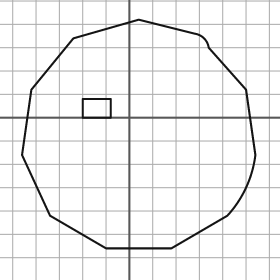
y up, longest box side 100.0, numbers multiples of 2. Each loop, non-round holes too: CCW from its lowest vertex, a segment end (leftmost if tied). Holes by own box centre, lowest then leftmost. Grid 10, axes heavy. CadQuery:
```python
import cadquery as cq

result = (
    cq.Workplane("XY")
    .moveTo(-10.0, -56.0)
    .lineTo(18.0, -56.0)
    .lineTo(42.0, -42.0)
    .threePointArc((50.0, -30.0), (54.0, -16.0))
    .lineTo(50.0, 12.0)
    .lineTo(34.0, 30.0)
    .threePointArc((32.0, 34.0), (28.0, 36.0))
    .lineTo(4.0, 42.0)
    .lineTo(-24.0, 34.0)
    .lineTo(-42.0, 12.0)
    .lineTo(-46.0, -16.0)
    .lineTo(-34.0, -42.0)
    .close()
    .moveTo(-20.0, 0.0)
    .lineTo(-8.0, 0.0)
    .lineTo(-8.0, 8.0)
    .lineTo(-20.0, 8.0)
    .close()
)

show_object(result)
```